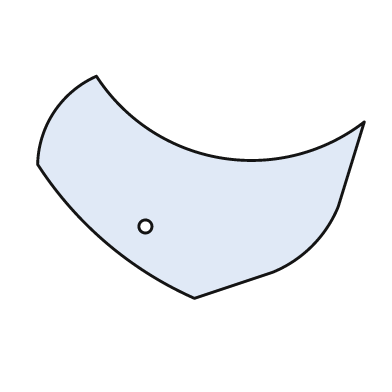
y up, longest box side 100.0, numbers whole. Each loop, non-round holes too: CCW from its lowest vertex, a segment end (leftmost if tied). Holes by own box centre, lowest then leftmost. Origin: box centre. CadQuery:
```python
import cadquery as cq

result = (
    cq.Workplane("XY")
    .moveTo(-2.0, -34.0)
    .lineTo(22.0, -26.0)
    .threePointArc((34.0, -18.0), (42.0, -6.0))
    .lineTo(50.0, 20.0)
    .threePointArc((6.0, 9.0), (-32.0, 34.0))
    .threePointArc((-45.0, 23.0), (-50.0, 7.0))
    .threePointArc((-29.0, -17.0), (-2.0, -34.0))
    .close()
    .moveTo(-17.0, -12.0)
    .circle(2.0)
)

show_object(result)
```